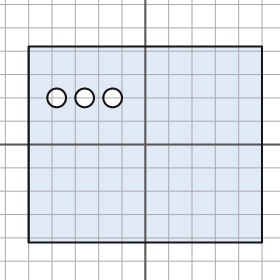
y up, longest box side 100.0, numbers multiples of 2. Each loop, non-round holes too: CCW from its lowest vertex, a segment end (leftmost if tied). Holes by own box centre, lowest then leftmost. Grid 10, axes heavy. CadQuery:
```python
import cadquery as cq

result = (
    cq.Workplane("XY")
    .moveTo(-50.0, -42.0)
    .lineTo(50.0, -42.0)
    .lineTo(50.0, 42.0)
    .lineTo(-50.0, 42.0)
    .close()
    .moveTo(-38.0, 20.0)
    .circle(4.0)
    .moveTo(-26.0, 20.0)
    .circle(4.0)
    .moveTo(-14.0, 20.0)
    .circle(4.0)
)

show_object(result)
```